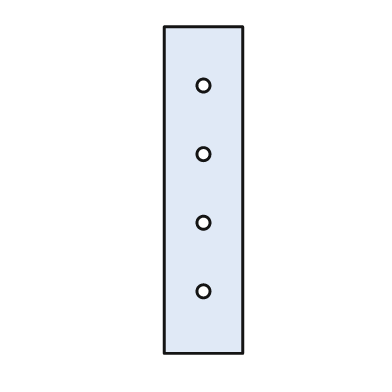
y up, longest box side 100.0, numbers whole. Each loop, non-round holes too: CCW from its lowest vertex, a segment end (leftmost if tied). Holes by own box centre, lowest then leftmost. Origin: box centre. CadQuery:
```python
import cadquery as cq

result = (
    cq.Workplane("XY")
    .moveTo(-12.0, -50.0)
    .lineTo(12.0, -50.0)
    .lineTo(12.0, 50.0)
    .lineTo(-12.0, 50.0)
    .close()
    .moveTo(0.0, -31.0)
    .circle(2.0)
    .moveTo(0.0, -10.0)
    .circle(2.0)
    .moveTo(0.0, 11.0)
    .circle(2.0)
    .moveTo(0.0, 32.0)
    .circle(2.0)
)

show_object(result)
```